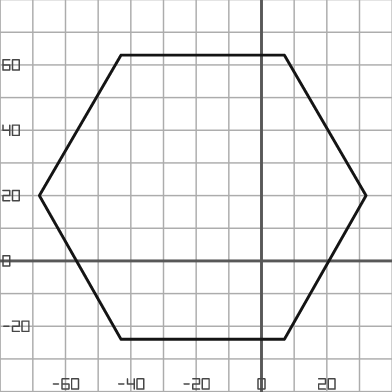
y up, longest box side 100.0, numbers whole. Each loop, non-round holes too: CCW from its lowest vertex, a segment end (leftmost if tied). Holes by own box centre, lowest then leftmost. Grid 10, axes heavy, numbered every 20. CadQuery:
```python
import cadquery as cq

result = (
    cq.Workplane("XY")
    .moveTo(-43.0, -24.0)
    .lineTo(7.0, -24.0)
    .lineTo(32.0, 20.0)
    .lineTo(7.0, 63.0)
    .lineTo(-43.0, 63.0)
    .lineTo(-68.0, 20.0)
    .close()
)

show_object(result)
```